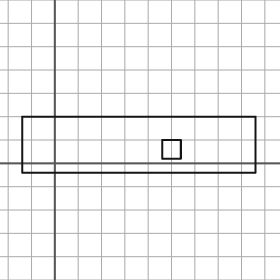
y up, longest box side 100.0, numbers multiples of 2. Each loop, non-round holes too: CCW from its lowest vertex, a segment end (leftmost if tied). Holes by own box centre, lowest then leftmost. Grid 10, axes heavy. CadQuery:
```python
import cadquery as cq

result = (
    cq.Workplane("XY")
    .moveTo(-14.0, -4.0)
    .lineTo(86.0, -4.0)
    .lineTo(86.0, 20.0)
    .lineTo(-14.0, 20.0)
    .close()
    .moveTo(46.0, 2.0)
    .lineTo(54.0, 2.0)
    .lineTo(54.0, 10.0)
    .lineTo(46.0, 10.0)
    .close()
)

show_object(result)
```